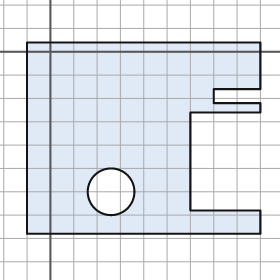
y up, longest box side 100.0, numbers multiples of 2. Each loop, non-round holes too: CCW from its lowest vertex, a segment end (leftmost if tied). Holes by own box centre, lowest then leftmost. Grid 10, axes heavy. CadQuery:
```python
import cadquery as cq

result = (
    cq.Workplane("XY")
    .moveTo(-10.0, -78.0)
    .lineTo(90.0, -78.0)
    .lineTo(90.0, -68.0)
    .lineTo(60.0, -68.0)
    .lineTo(60.0, -26.0)
    .lineTo(90.0, -26.0)
    .lineTo(90.0, -22.0)
    .lineTo(70.0, -22.0)
    .lineTo(70.0, -16.0)
    .lineTo(90.0, -16.0)
    .lineTo(90.0, 4.0)
    .lineTo(-10.0, 4.0)
    .close()
    .moveTo(26.0, -60.0)
    .circle(10.0)
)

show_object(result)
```